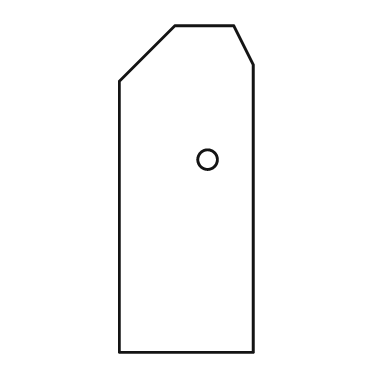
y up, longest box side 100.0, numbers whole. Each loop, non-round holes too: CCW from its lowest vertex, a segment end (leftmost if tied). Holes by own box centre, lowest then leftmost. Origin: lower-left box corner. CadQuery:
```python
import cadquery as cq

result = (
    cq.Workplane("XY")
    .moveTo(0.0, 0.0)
    .lineTo(41.0, 0.0)
    .lineTo(41.0, 88.0)
    .lineTo(35.0, 100.0)
    .lineTo(17.0, 100.0)
    .lineTo(0.0, 83.0)
    .close()
    .moveTo(27.0, 59.0)
    .circle(3.0)
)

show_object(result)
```